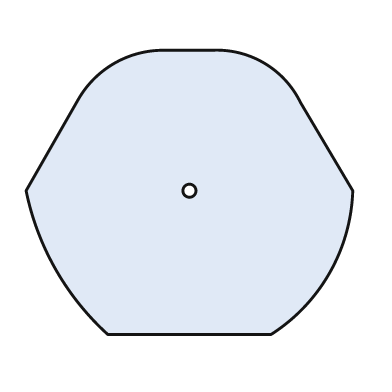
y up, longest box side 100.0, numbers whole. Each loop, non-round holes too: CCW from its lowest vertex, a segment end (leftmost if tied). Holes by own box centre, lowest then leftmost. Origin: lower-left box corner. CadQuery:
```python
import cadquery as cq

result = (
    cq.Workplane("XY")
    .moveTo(25.0, 0.0)
    .lineTo(75.0, 0.0)
    .threePointArc((93.0, 19.0), (100.0, 44.0))
    .lineTo(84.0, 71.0)
    .threePointArc((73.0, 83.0), (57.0, 87.0))
    .lineTo(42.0, 87.0)
    .threePointArc((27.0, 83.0), (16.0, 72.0))
    .lineTo(0.0, 44.0)
    .threePointArc((9.0, 20.0), (25.0, 0.0))
    .close()
    .moveTo(50.0, 44.0)
    .circle(2.0)
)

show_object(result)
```